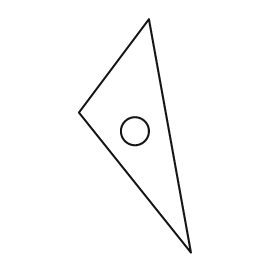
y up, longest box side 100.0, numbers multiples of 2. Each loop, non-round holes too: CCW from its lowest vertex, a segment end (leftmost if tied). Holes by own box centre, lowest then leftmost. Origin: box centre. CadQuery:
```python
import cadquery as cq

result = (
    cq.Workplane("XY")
    .moveTo(24.0, -50.0)
    .lineTo(6.0, 50.0)
    .lineTo(-24.0, 10.0)
    .close()
    .moveTo(0.0, 2.0)
    .circle(6.0)
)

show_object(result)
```